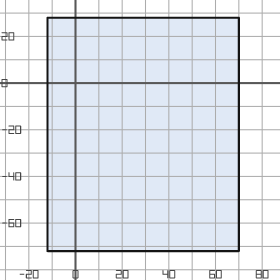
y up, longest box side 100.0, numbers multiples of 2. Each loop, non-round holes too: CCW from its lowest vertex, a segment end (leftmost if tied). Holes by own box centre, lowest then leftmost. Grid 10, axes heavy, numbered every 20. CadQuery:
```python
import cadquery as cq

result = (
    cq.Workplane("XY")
    .moveTo(-12.0, -72.0)
    .lineTo(70.0, -72.0)
    .lineTo(70.0, 28.0)
    .lineTo(-12.0, 28.0)
    .close()
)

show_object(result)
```